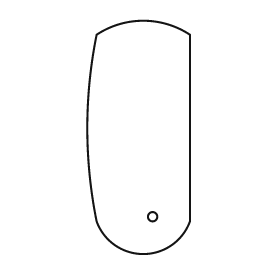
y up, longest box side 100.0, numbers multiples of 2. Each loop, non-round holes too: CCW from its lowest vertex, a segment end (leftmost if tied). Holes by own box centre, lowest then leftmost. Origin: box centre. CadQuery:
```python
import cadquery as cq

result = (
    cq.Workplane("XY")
    .moveTo(-18.0, -36.0)
    .threePointArc((2.0, -50.0), (22.0, -36.0))
    .lineTo(22.0, 44.0)
    .threePointArc((2.0, 50.0), (-18.0, 44.0))
    .threePointArc((-22.0, 4.0), (-18.0, -36.0))
    .close()
    .moveTo(6.0, -34.0)
    .circle(2.0)
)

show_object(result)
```